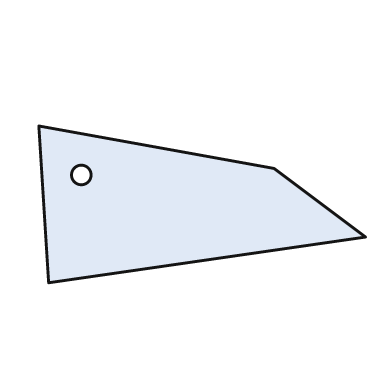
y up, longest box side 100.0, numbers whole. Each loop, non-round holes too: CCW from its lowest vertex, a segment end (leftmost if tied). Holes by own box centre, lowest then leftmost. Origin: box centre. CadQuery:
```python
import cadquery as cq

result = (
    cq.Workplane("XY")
    .moveTo(-47.0, -24.0)
    .lineTo(50.0, -10.0)
    .lineTo(22.0, 11.0)
    .lineTo(-50.0, 24.0)
    .close()
    .moveTo(-37.0, 9.0)
    .circle(3.0)
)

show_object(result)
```